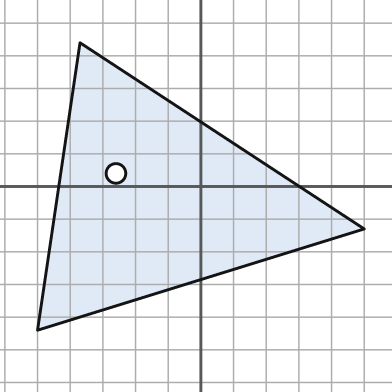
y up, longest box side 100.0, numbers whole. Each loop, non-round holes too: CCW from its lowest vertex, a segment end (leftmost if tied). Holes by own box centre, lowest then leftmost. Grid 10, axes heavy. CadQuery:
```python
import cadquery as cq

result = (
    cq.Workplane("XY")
    .moveTo(-50.0, -44.0)
    .lineTo(50.0, -13.0)
    .lineTo(-37.0, 44.0)
    .close()
    .moveTo(-26.0, 4.0)
    .circle(3.0)
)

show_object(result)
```